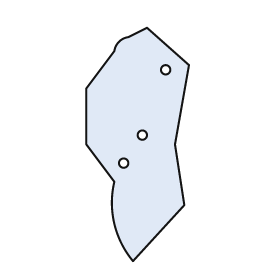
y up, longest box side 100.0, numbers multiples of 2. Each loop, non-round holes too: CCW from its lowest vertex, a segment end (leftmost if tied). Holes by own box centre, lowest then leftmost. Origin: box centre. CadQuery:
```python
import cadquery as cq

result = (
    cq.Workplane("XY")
    .moveTo(-2.0, -50.0)
    .lineTo(20.0, -26.0)
    .lineTo(16.0, 0.0)
    .lineTo(22.0, 34.0)
    .lineTo(4.0, 50.0)
    .lineTo(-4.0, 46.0)
    .threePointArc((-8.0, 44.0), (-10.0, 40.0))
    .lineTo(-22.0, 24.0)
    .lineTo(-22.0, 0.0)
    .lineTo(-10.0, -16.0)
    .threePointArc((-10.0, -34.0), (-2.0, -50.0))
    .close()
    .moveTo(-6.0, -8.0)
    .circle(2.0)
    .moveTo(2.0, 4.0)
    .circle(2.0)
    .moveTo(12.0, 32.0)
    .circle(2.0)
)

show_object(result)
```